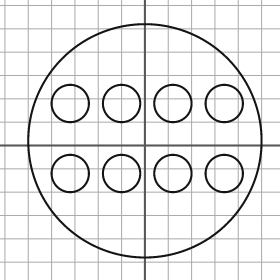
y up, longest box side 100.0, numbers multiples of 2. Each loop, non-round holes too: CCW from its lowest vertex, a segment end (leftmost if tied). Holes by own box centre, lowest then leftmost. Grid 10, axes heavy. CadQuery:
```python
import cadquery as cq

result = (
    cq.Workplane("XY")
    .moveTo(0.0, 2.0)
    .circle(50.0)
    .moveTo(-32.0, -12.0)
    .circle(8.0)
    .moveTo(-10.0, -12.0)
    .circle(8.0)
    .moveTo(12.0, -12.0)
    .circle(8.0)
    .moveTo(34.0, -12.0)
    .circle(8.0)
    .moveTo(-32.0, 18.0)
    .circle(8.0)
    .moveTo(-10.0, 18.0)
    .circle(8.0)
    .moveTo(12.0, 18.0)
    .circle(8.0)
    .moveTo(34.0, 18.0)
    .circle(8.0)
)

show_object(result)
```